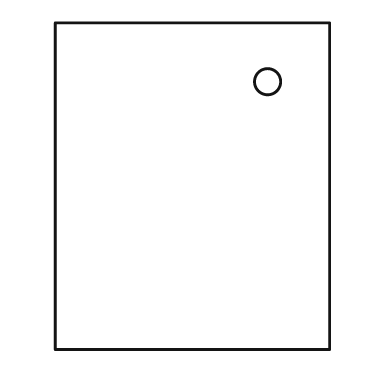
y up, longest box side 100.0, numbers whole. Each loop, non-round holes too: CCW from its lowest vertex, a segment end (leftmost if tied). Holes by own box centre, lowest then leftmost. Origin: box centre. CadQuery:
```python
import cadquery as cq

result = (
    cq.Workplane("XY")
    .moveTo(-42.0, -50.0)
    .lineTo(42.0, -50.0)
    .lineTo(42.0, 50.0)
    .lineTo(-42.0, 50.0)
    .close()
    .moveTo(23.0, 32.0)
    .circle(4.0)
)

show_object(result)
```